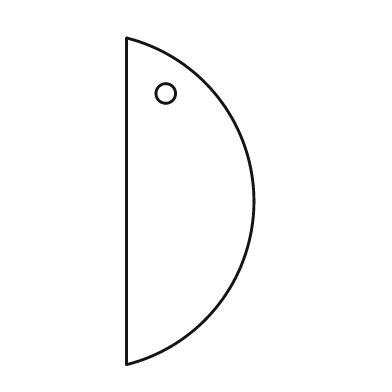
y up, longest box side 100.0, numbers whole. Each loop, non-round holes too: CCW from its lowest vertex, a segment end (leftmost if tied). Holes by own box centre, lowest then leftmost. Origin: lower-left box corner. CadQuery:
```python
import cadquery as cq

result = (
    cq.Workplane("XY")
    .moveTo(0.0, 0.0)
    .threePointArc((39.0, 50.0), (0.0, 100.0))
    .close()
    .moveTo(12.0, 83.0)
    .circle(3.0)
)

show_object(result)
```